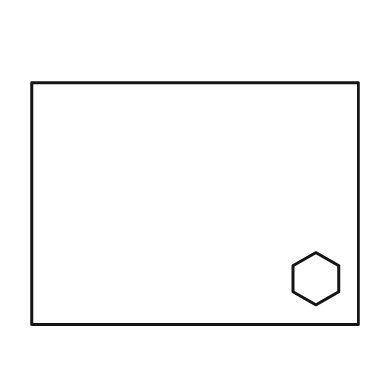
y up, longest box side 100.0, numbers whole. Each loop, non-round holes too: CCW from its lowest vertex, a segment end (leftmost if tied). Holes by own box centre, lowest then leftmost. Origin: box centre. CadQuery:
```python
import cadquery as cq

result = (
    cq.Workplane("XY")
    .moveTo(-50.0, -37.0)
    .lineTo(50.0, -37.0)
    .lineTo(50.0, 37.0)
    .lineTo(-50.0, 37.0)
    .close()
    .moveTo(37.0, -31.0)
    .lineTo(44.0, -27.0)
    .lineTo(44.0, -19.0)
    .lineTo(37.0, -15.0)
    .lineTo(30.0, -19.0)
    .lineTo(30.0, -27.0)
    .close()
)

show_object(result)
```